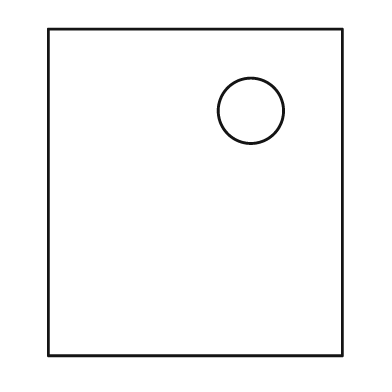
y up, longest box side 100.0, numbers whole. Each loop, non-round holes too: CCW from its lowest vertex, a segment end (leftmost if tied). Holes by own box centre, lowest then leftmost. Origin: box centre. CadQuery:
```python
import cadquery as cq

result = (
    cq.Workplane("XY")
    .moveTo(-45.0, -50.0)
    .lineTo(45.0, -50.0)
    .lineTo(45.0, 50.0)
    .lineTo(-45.0, 50.0)
    .close()
    .moveTo(17.0, 25.0)
    .circle(10.0)
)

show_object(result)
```